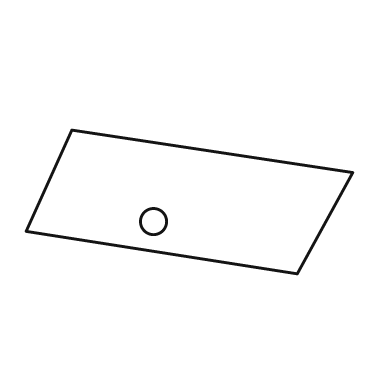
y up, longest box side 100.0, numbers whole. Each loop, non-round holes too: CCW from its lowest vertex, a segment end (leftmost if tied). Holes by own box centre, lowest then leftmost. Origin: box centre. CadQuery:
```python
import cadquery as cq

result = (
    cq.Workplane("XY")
    .moveTo(33.0, -22.0)
    .lineTo(50.0, 9.0)
    .lineTo(-36.0, 22.0)
    .lineTo(-50.0, -9.0)
    .close()
    .moveTo(-11.0, -6.0)
    .circle(4.0)
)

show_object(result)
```